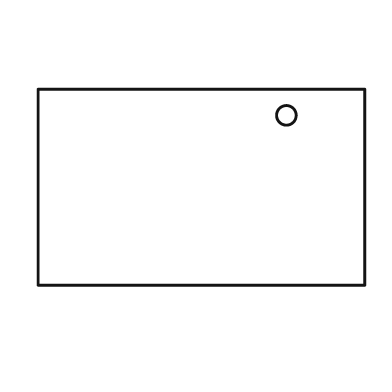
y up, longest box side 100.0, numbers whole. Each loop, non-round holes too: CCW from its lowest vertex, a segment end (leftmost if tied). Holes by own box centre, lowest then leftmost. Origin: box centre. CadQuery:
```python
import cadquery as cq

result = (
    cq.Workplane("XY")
    .moveTo(-50.0, -30.0)
    .lineTo(50.0, -30.0)
    .lineTo(50.0, 30.0)
    .lineTo(-50.0, 30.0)
    .close()
    .moveTo(26.0, 22.0)
    .circle(3.0)
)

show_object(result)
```